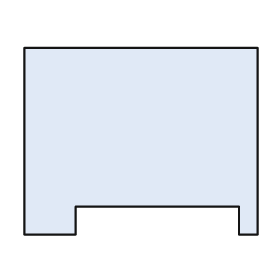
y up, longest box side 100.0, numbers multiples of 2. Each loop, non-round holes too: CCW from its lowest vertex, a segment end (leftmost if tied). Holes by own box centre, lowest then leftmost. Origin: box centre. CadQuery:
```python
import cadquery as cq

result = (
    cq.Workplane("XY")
    .moveTo(-50.0, -40.0)
    .lineTo(-28.0, -40.0)
    .lineTo(-28.0, -28.0)
    .lineTo(42.0, -28.0)
    .lineTo(42.0, -40.0)
    .lineTo(50.0, -40.0)
    .lineTo(50.0, 40.0)
    .lineTo(-50.0, 40.0)
    .close()
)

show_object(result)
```